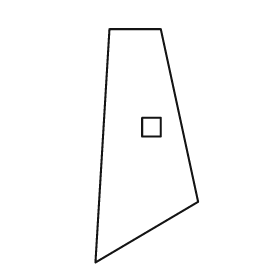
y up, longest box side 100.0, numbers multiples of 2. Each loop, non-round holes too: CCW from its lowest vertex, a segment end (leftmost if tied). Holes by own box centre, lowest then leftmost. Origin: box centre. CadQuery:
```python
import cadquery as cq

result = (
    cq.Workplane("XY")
    .moveTo(-22.0, -50.0)
    .lineTo(22.0, -24.0)
    .lineTo(6.0, 50.0)
    .lineTo(-16.0, 50.0)
    .close()
    .moveTo(-2.0, 4.0)
    .lineTo(6.0, 4.0)
    .lineTo(6.0, 12.0)
    .lineTo(-2.0, 12.0)
    .close()
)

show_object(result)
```